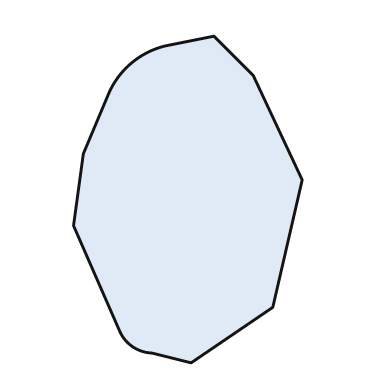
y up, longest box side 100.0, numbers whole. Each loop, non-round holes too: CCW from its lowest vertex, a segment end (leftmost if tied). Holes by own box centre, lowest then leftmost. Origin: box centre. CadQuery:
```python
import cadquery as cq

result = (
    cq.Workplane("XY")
    .moveTo(1.0, -50.0)
    .lineTo(26.0, -33.0)
    .lineTo(35.0, 6.0)
    .lineTo(20.0, 38.0)
    .lineTo(8.0, 50.0)
    .lineTo(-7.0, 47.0)
    .threePointArc((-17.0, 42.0), (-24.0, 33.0))
    .lineTo(-32.0, 14.0)
    .lineTo(-35.0, -8.0)
    .lineTo(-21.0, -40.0)
    .threePointArc((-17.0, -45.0), (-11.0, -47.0))
    .close()
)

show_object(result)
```